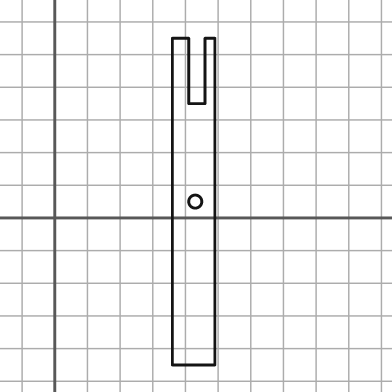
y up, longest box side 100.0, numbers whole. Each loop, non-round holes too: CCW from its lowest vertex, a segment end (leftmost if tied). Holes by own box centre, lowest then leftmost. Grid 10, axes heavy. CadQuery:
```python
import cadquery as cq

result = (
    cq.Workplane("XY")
    .moveTo(36.0, -45.0)
    .lineTo(49.0, -45.0)
    .lineTo(49.0, 55.0)
    .lineTo(46.0, 55.0)
    .lineTo(46.0, 35.0)
    .lineTo(41.0, 35.0)
    .lineTo(41.0, 55.0)
    .lineTo(36.0, 55.0)
    .close()
    .moveTo(43.0, 5.0)
    .circle(2.0)
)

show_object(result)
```